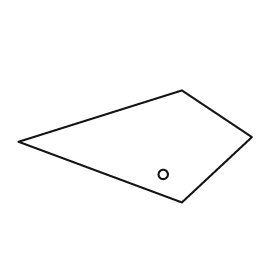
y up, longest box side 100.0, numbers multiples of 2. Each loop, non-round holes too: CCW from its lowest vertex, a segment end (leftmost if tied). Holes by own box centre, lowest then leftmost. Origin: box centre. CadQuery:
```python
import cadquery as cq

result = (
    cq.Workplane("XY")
    .moveTo(20.0, -24.0)
    .lineTo(50.0, 4.0)
    .lineTo(20.0, 24.0)
    .lineTo(-50.0, 2.0)
    .close()
    .moveTo(12.0, -12.0)
    .circle(2.0)
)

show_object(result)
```